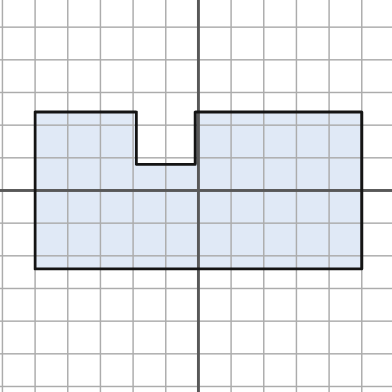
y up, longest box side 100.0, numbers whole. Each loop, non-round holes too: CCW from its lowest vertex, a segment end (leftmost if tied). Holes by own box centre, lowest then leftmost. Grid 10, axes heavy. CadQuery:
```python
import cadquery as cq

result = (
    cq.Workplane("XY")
    .moveTo(-50.0, -24.0)
    .lineTo(50.0, -24.0)
    .lineTo(50.0, 24.0)
    .lineTo(-1.0, 24.0)
    .lineTo(-1.0, 8.0)
    .lineTo(-19.0, 8.0)
    .lineTo(-19.0, 24.0)
    .lineTo(-50.0, 24.0)
    .close()
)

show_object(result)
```